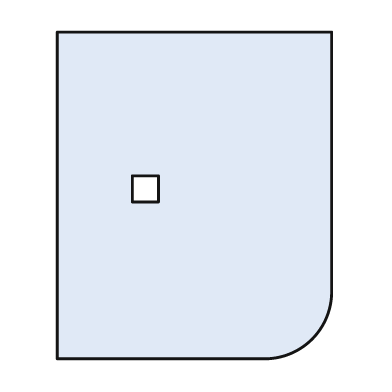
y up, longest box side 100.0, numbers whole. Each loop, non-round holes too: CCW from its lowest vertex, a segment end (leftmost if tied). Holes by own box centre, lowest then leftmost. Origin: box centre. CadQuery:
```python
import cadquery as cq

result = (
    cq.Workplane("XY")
    .moveTo(-42.0, -50.0)
    .lineTo(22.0, -50.0)
    .threePointArc((36.0, -44.0), (42.0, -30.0))
    .lineTo(42.0, 50.0)
    .lineTo(-42.0, 50.0)
    .close()
    .moveTo(-19.0, -2.0)
    .lineTo(-11.0, -2.0)
    .lineTo(-11.0, 6.0)
    .lineTo(-19.0, 6.0)
    .close()
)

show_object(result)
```